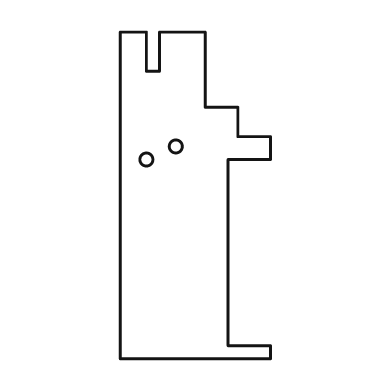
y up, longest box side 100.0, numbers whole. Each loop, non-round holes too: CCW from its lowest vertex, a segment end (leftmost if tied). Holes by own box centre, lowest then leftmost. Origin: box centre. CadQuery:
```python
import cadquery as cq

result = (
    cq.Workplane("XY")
    .moveTo(-23.0, -50.0)
    .lineTo(23.0, -50.0)
    .lineTo(23.0, -46.0)
    .lineTo(10.0, -46.0)
    .lineTo(10.0, 11.0)
    .lineTo(23.0, 11.0)
    .lineTo(23.0, 18.0)
    .lineTo(13.0, 18.0)
    .lineTo(13.0, 27.0)
    .lineTo(3.0, 27.0)
    .lineTo(3.0, 50.0)
    .lineTo(-11.0, 50.0)
    .lineTo(-11.0, 38.0)
    .lineTo(-15.0, 38.0)
    .lineTo(-15.0, 50.0)
    .lineTo(-23.0, 50.0)
    .close()
    .moveTo(-15.0, 11.0)
    .circle(2.0)
    .moveTo(-6.0, 15.0)
    .circle(2.0)
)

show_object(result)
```